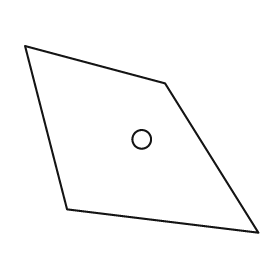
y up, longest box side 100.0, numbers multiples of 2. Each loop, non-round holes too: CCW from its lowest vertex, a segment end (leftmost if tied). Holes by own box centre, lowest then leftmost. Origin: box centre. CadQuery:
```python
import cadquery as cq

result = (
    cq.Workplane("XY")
    .moveTo(50.0, -40.0)
    .lineTo(10.0, 24.0)
    .lineTo(-50.0, 40.0)
    .lineTo(-32.0, -30.0)
    .close()
    .moveTo(0.0, 0.0)
    .circle(4.0)
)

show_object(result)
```